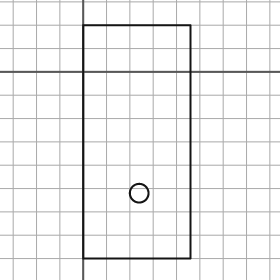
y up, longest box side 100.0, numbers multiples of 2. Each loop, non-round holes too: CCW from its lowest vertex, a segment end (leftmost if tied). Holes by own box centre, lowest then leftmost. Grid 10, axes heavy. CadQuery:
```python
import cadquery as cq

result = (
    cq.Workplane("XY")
    .moveTo(0.0, -80.0)
    .lineTo(46.0, -80.0)
    .lineTo(46.0, 20.0)
    .lineTo(0.0, 20.0)
    .close()
    .moveTo(24.0, -52.0)
    .circle(4.0)
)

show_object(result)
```